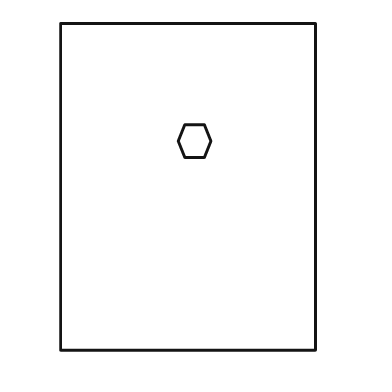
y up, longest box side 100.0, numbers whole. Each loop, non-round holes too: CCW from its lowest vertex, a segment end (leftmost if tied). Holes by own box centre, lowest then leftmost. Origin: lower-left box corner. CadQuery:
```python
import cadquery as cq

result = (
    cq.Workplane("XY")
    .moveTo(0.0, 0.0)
    .lineTo(78.0, 0.0)
    .lineTo(78.0, 100.0)
    .lineTo(0.0, 100.0)
    .close()
    .moveTo(38.0, 59.0)
    .lineTo(44.0, 59.0)
    .lineTo(46.0, 64.0)
    .lineTo(44.0, 69.0)
    .lineTo(38.0, 69.0)
    .lineTo(36.0, 64.0)
    .close()
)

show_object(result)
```